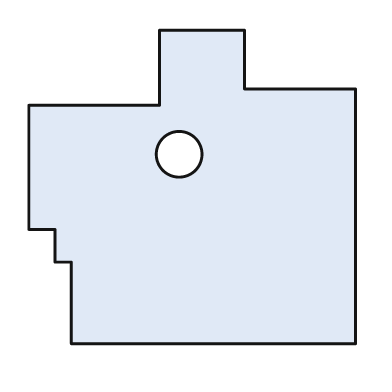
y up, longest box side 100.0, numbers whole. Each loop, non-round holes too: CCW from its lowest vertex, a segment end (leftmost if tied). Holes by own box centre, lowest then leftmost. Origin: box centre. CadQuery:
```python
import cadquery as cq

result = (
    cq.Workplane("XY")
    .moveTo(-37.0, -48.0)
    .lineTo(50.0, -48.0)
    .lineTo(50.0, 30.0)
    .lineTo(16.0, 30.0)
    .lineTo(16.0, 48.0)
    .lineTo(-10.0, 48.0)
    .lineTo(-10.0, 25.0)
    .lineTo(-50.0, 25.0)
    .lineTo(-50.0, -13.0)
    .lineTo(-42.0, -13.0)
    .lineTo(-42.0, -23.0)
    .lineTo(-37.0, -23.0)
    .close()
    .moveTo(-4.0, 10.0)
    .circle(7.0)
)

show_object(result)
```